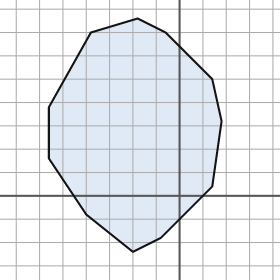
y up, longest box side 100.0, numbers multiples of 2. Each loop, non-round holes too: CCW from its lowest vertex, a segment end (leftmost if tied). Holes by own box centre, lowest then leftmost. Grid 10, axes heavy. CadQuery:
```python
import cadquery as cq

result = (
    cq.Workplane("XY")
    .moveTo(-20.0, -24.0)
    .lineTo(-8.0, -18.0)
    .lineTo(14.0, 4.0)
    .lineTo(18.0, 32.0)
    .lineTo(14.0, 50.0)
    .lineTo(-6.0, 70.0)
    .lineTo(-18.0, 76.0)
    .lineTo(-38.0, 70.0)
    .lineTo(-56.0, 38.0)
    .lineTo(-56.0, 16.0)
    .lineTo(-40.0, -8.0)
    .close()
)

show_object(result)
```